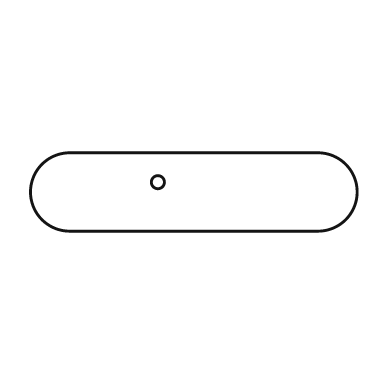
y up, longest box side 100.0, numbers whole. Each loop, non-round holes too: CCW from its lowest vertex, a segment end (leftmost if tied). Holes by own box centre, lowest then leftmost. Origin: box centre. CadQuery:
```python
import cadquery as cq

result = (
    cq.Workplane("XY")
    .moveTo(-38.0, -12.0)
    .lineTo(38.0, -12.0)
    .threePointArc((50.0, 0.0), (38.0, 12.0))
    .lineTo(-38.0, 12.0)
    .threePointArc((-50.0, 0.0), (-38.0, -12.0))
    .close()
    .moveTo(-11.0, 3.0)
    .circle(2.0)
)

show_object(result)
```